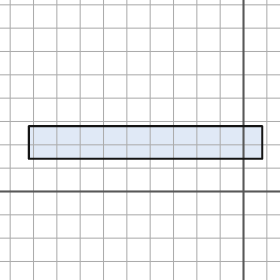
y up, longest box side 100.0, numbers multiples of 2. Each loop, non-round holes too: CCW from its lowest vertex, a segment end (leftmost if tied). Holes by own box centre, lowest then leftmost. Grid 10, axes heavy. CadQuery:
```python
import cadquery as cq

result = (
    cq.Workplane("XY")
    .moveTo(-92.0, 14.0)
    .lineTo(8.0, 14.0)
    .lineTo(8.0, 28.0)
    .lineTo(-92.0, 28.0)
    .close()
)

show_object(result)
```